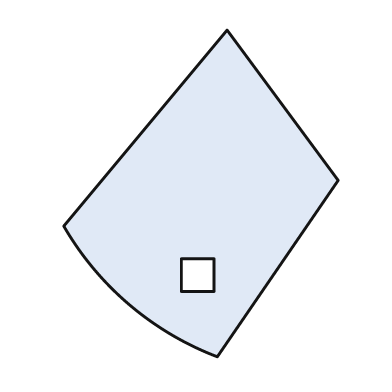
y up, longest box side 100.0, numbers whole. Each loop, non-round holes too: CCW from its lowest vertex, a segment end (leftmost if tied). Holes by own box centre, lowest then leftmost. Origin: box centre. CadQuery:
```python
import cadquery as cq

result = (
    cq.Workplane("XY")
    .moveTo(5.0, -50.0)
    .lineTo(42.0, 4.0)
    .lineTo(8.0, 50.0)
    .lineTo(-42.0, -10.0)
    .threePointArc((-22.0, -34.0), (5.0, -50.0))
    .close()
    .moveTo(-6.0, -30.0)
    .lineTo(4.0, -30.0)
    .lineTo(4.0, -20.0)
    .lineTo(-6.0, -20.0)
    .close()
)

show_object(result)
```